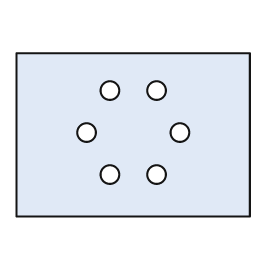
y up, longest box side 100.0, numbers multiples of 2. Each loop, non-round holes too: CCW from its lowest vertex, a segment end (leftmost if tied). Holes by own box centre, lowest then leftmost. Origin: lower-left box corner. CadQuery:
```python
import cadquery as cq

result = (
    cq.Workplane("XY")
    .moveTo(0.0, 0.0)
    .lineTo(100.0, 0.0)
    .lineTo(100.0, 70.0)
    .lineTo(0.0, 70.0)
    .close()
    .moveTo(40.0, 18.0)
    .circle(4.0)
    .moveTo(60.0, 18.0)
    .circle(4.0)
    .moveTo(30.0, 36.0)
    .circle(4.0)
    .moveTo(70.0, 36.0)
    .circle(4.0)
    .moveTo(40.0, 54.0)
    .circle(4.0)
    .moveTo(60.0, 54.0)
    .circle(4.0)
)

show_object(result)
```